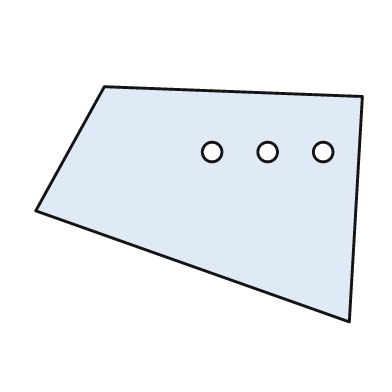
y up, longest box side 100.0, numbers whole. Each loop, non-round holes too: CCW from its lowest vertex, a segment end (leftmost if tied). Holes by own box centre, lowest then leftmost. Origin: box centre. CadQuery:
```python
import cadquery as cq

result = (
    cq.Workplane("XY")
    .moveTo(46.0, -36.0)
    .lineTo(50.0, 33.0)
    .lineTo(-29.0, 36.0)
    .lineTo(-50.0, -2.0)
    .close()
    .moveTo(4.0, 16.0)
    .circle(3.0)
    .moveTo(21.0, 16.0)
    .circle(3.0)
    .moveTo(38.0, 16.0)
    .circle(3.0)
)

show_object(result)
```